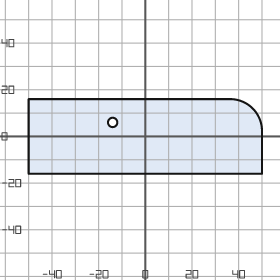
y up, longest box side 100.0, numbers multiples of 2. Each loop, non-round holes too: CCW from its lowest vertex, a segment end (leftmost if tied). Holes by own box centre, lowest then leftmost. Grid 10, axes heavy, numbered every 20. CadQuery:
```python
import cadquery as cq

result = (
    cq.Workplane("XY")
    .moveTo(-50.0, -16.0)
    .lineTo(50.0, -16.0)
    .lineTo(50.0, 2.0)
    .threePointArc((46.0, 12.0), (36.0, 16.0))
    .lineTo(-50.0, 16.0)
    .close()
    .moveTo(-14.0, 6.0)
    .circle(2.0)
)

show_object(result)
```